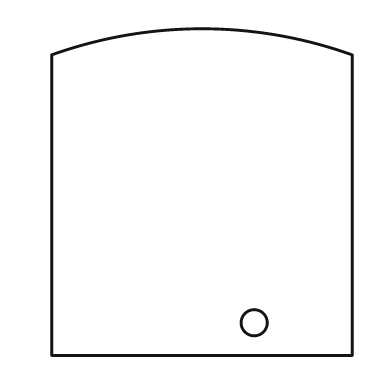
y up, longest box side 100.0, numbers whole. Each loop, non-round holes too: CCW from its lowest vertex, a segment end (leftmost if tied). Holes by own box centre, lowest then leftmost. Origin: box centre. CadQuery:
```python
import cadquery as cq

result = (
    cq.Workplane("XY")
    .moveTo(-46.0, -50.0)
    .lineTo(46.0, -50.0)
    .lineTo(46.0, 42.0)
    .threePointArc((0.0, 50.0), (-46.0, 42.0))
    .close()
    .moveTo(16.0, -40.0)
    .circle(4.0)
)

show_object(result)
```